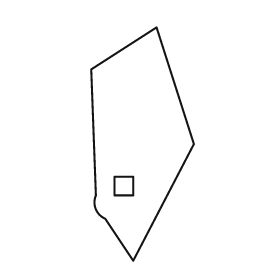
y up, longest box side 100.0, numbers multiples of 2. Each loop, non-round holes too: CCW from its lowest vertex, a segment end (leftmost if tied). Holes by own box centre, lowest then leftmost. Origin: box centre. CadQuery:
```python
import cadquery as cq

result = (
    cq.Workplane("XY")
    .moveTo(-4.0, -50.0)
    .lineTo(22.0, 0.0)
    .lineTo(6.0, 50.0)
    .lineTo(-22.0, 32.0)
    .lineTo(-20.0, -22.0)
    .threePointArc((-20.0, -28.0), (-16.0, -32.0))
    .close()
    .moveTo(-12.0, -22.0)
    .lineTo(-4.0, -22.0)
    .lineTo(-4.0, -14.0)
    .lineTo(-12.0, -14.0)
    .close()
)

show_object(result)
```